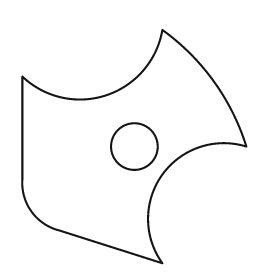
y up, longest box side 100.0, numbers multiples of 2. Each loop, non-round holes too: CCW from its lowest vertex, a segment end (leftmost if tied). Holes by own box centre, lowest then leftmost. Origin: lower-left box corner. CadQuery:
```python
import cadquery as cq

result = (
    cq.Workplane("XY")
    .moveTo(60.0, 0.0)
    .threePointArc((60.0, 38.0), (96.0, 50.0))
    .threePointArc((82.0, 78.0), (60.0, 100.0))
    .threePointArc((36.0, 72.0), (0.0, 80.0))
    .lineTo(0.0, 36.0)
    .threePointArc((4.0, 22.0), (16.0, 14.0))
    .close()
    .moveTo(48.0, 50.0)
    .circle(10.0)
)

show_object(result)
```